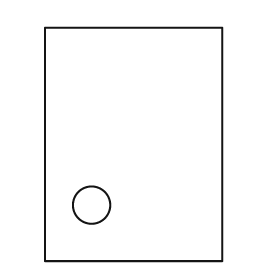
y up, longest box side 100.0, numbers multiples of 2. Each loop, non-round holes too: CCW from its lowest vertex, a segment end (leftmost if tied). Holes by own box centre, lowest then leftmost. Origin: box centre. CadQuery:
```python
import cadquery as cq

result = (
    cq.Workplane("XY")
    .moveTo(-38.0, -50.0)
    .lineTo(38.0, -50.0)
    .lineTo(38.0, 50.0)
    .lineTo(-38.0, 50.0)
    .close()
    .moveTo(-18.0, -26.0)
    .circle(8.0)
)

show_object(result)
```